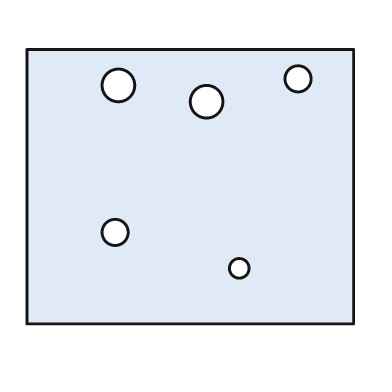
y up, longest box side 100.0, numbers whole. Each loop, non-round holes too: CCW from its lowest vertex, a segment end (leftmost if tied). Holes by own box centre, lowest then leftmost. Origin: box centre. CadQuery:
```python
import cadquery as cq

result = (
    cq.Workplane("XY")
    .moveTo(-50.0, -42.0)
    .lineTo(50.0, -42.0)
    .lineTo(50.0, 42.0)
    .lineTo(-50.0, 42.0)
    .close()
    .moveTo(15.0, -25.0)
    .circle(3.0)
    .moveTo(-23.0, -14.0)
    .circle(4.0)
    .moveTo(5.0, 26.0)
    .circle(5.0)
    .moveTo(-22.0, 31.0)
    .circle(5.0)
    .moveTo(33.0, 33.0)
    .circle(4.0)
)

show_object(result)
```